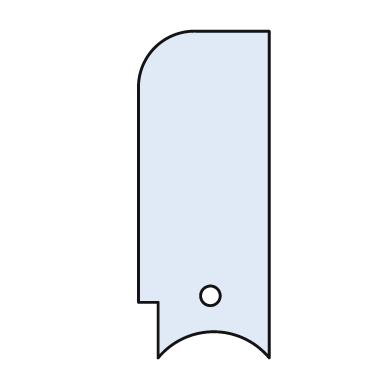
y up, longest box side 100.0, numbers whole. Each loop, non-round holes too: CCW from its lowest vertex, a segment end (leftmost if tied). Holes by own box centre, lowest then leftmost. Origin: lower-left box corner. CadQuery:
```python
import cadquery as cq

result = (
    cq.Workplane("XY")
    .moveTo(6.0, 0.0)
    .threePointArc((23.0, 8.0), (40.0, 0.0))
    .lineTo(40.0, 100.0)
    .lineTo(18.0, 100.0)
    .threePointArc((5.0, 95.0), (0.0, 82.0))
    .lineTo(0.0, 17.0)
    .lineTo(6.0, 17.0)
    .close()
    .moveTo(22.0, 19.0)
    .circle(3.0)
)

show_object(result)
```